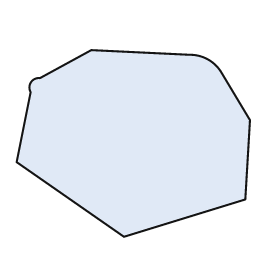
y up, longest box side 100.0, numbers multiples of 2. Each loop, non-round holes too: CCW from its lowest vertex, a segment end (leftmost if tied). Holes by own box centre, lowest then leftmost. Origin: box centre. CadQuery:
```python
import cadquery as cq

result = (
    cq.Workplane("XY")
    .moveTo(-4.0, -40.0)
    .lineTo(48.0, -24.0)
    .lineTo(50.0, 10.0)
    .lineTo(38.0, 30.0)
    .threePointArc((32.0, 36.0), (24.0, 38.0))
    .lineTo(-18.0, 40.0)
    .lineTo(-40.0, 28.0)
    .threePointArc((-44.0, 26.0), (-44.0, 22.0))
    .lineTo(-50.0, -8.0)
    .close()
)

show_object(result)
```